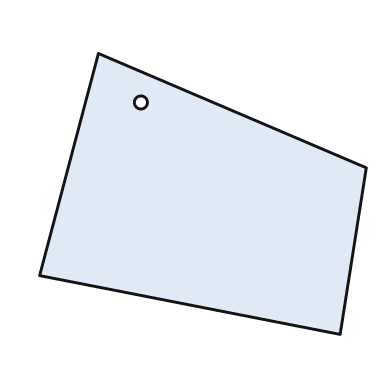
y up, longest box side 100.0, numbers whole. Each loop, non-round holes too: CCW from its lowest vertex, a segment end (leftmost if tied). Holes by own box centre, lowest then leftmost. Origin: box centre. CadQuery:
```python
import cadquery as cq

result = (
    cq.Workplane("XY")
    .moveTo(42.0, -43.0)
    .lineTo(50.0, 8.0)
    .lineTo(-32.0, 43.0)
    .lineTo(-50.0, -25.0)
    .close()
    .moveTo(-19.0, 28.0)
    .circle(2.0)
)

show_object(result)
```